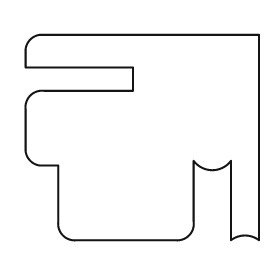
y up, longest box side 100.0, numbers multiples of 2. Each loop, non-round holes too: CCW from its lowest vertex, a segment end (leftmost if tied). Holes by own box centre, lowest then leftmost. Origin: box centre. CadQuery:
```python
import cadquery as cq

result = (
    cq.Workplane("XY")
    .moveTo(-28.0, -44.0)
    .lineTo(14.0, -44.0)
    .threePointArc((20.0, -42.0), (22.0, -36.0))
    .lineTo(22.0, -10.0)
    .threePointArc((30.0, -14.0), (38.0, -10.0))
    .lineTo(38.0, -44.0)
    .threePointArc((44.0, -42.0), (50.0, -44.0))
    .lineTo(50.0, 44.0)
    .lineTo(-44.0, 44.0)
    .threePointArc((-48.0, 42.0), (-50.0, 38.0))
    .lineTo(-50.0, 30.0)
    .lineTo(-4.0, 30.0)
    .lineTo(-4.0, 20.0)
    .lineTo(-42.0, 20.0)
    .threePointArc((-48.0, 18.0), (-50.0, 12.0))
    .lineTo(-50.0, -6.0)
    .threePointArc((-48.0, -10.0), (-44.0, -12.0))
    .lineTo(-36.0, -12.0)
    .lineTo(-36.0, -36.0)
    .threePointArc((-34.0, -42.0), (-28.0, -44.0))
    .close()
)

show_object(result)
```